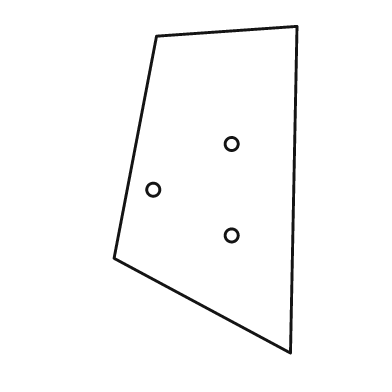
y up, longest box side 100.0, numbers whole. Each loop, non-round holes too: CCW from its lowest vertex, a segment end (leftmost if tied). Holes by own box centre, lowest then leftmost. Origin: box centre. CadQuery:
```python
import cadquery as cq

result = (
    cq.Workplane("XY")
    .moveTo(26.0, -50.0)
    .lineTo(28.0, 50.0)
    .lineTo(-15.0, 47.0)
    .lineTo(-28.0, -21.0)
    .close()
    .moveTo(8.0, -14.0)
    .circle(2.0)
    .moveTo(-16.0, 0.0)
    .circle(2.0)
    .moveTo(8.0, 14.0)
    .circle(2.0)
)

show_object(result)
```